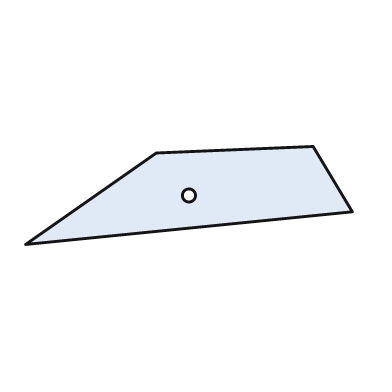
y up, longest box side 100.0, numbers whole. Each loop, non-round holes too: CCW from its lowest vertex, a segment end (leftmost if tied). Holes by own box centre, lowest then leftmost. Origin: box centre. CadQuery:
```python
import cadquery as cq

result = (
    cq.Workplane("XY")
    .moveTo(-50.0, -15.0)
    .lineTo(50.0, -5.0)
    .lineTo(38.0, 15.0)
    .lineTo(-10.0, 13.0)
    .close()
    .moveTo(0.0, 0.0)
    .circle(2.0)
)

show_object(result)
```